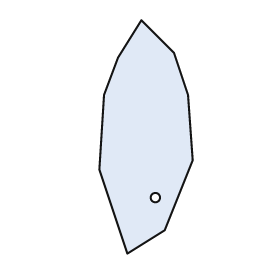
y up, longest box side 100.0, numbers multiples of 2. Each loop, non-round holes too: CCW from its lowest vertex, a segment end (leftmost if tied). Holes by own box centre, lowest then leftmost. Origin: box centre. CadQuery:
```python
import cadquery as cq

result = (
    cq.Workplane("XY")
    .moveTo(-8.0, -50.0)
    .lineTo(8.0, -40.0)
    .lineTo(20.0, -10.0)
    .lineTo(18.0, 18.0)
    .lineTo(12.0, 36.0)
    .lineTo(-2.0, 50.0)
    .lineTo(-12.0, 34.0)
    .lineTo(-18.0, 18.0)
    .lineTo(-20.0, -14.0)
    .close()
    .moveTo(4.0, -26.0)
    .circle(2.0)
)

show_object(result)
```